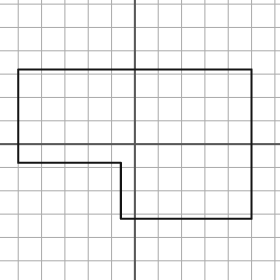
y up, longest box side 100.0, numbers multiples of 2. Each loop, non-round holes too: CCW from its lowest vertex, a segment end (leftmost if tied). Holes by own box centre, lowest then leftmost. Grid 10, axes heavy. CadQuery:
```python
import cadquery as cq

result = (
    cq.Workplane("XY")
    .moveTo(-6.0, -32.0)
    .lineTo(50.0, -32.0)
    .lineTo(50.0, 32.0)
    .lineTo(-50.0, 32.0)
    .lineTo(-50.0, -8.0)
    .lineTo(-6.0, -8.0)
    .close()
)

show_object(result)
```